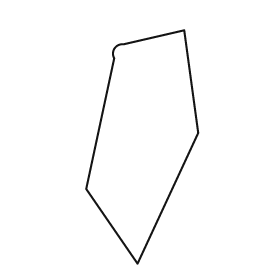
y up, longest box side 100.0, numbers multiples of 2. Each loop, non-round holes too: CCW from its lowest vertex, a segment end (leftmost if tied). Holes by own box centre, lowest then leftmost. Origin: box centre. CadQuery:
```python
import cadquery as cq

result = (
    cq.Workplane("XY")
    .moveTo(-2.0, -50.0)
    .lineTo(24.0, 6.0)
    .lineTo(18.0, 50.0)
    .lineTo(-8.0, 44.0)
    .threePointArc((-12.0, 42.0), (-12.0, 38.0))
    .lineTo(-24.0, -18.0)
    .close()
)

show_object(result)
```